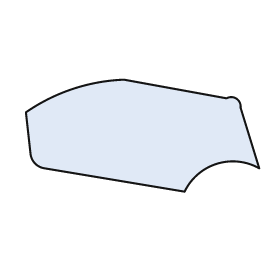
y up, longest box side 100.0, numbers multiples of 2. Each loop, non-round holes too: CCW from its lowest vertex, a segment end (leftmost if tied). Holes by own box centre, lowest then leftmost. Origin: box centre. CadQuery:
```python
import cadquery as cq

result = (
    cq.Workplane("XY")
    .moveTo(18.0, -24.0)
    .threePointArc((32.0, -12.0), (50.0, -14.0))
    .lineTo(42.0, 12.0)
    .threePointArc((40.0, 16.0), (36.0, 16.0))
    .lineTo(-8.0, 24.0)
    .threePointArc((-30.0, 20.0), (-50.0, 10.0))
    .lineTo(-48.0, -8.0)
    .threePointArc((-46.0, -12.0), (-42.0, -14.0))
    .close()
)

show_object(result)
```